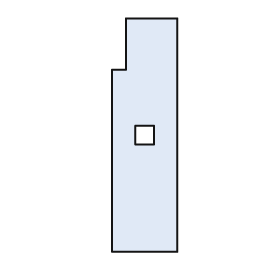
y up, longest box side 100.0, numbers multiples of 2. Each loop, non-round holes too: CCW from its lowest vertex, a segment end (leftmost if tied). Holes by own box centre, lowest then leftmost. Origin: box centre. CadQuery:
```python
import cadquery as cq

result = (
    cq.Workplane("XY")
    .moveTo(-14.0, -50.0)
    .lineTo(14.0, -50.0)
    .lineTo(14.0, 50.0)
    .lineTo(-8.0, 50.0)
    .lineTo(-8.0, 28.0)
    .lineTo(-14.0, 28.0)
    .close()
    .moveTo(-4.0, -4.0)
    .lineTo(4.0, -4.0)
    .lineTo(4.0, 4.0)
    .lineTo(-4.0, 4.0)
    .close()
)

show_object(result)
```